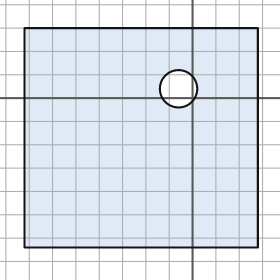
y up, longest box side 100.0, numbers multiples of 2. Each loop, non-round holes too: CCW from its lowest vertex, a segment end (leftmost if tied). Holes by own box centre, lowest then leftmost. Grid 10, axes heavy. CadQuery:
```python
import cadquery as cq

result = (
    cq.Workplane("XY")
    .moveTo(-72.0, -64.0)
    .lineTo(28.0, -64.0)
    .lineTo(28.0, 30.0)
    .lineTo(-72.0, 30.0)
    .close()
    .moveTo(-6.0, 4.0)
    .circle(8.0)
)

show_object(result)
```